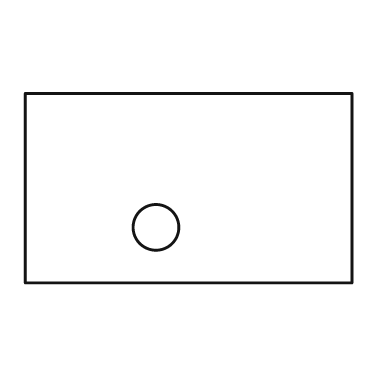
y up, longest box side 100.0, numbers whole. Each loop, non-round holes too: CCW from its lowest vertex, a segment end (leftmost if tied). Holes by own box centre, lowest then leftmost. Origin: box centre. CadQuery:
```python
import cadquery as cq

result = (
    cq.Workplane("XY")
    .moveTo(-50.0, -29.0)
    .lineTo(50.0, -29.0)
    .lineTo(50.0, 29.0)
    .lineTo(-50.0, 29.0)
    .close()
    .moveTo(-10.0, -12.0)
    .circle(7.0)
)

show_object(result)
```